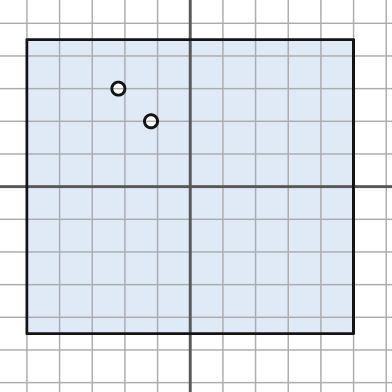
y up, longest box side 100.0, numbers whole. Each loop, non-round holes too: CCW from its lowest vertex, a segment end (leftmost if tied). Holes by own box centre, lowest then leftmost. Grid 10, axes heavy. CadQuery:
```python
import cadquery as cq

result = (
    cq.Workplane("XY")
    .moveTo(-50.0, -45.0)
    .lineTo(50.0, -45.0)
    .lineTo(50.0, 45.0)
    .lineTo(-50.0, 45.0)
    .close()
    .moveTo(-12.0, 20.0)
    .circle(2.0)
    .moveTo(-22.0, 30.0)
    .circle(2.0)
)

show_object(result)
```